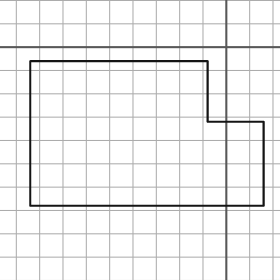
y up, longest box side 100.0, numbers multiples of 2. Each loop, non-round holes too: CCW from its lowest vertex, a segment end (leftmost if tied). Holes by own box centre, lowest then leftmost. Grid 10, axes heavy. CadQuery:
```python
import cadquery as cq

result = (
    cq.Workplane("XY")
    .moveTo(-84.0, -68.0)
    .lineTo(16.0, -68.0)
    .lineTo(16.0, -32.0)
    .lineTo(-8.0, -32.0)
    .lineTo(-8.0, -6.0)
    .lineTo(-84.0, -6.0)
    .close()
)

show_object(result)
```